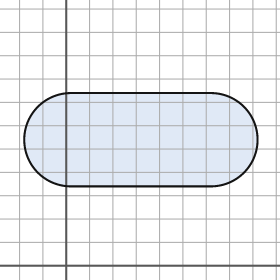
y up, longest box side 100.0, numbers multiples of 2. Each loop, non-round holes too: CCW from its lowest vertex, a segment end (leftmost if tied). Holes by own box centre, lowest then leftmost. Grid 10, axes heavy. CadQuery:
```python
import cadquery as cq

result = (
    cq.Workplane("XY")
    .moveTo(2.0, 34.0)
    .lineTo(62.0, 34.0)
    .threePointArc((82.0, 54.0), (62.0, 74.0))
    .lineTo(2.0, 74.0)
    .threePointArc((-18.0, 54.0), (2.0, 34.0))
    .close()
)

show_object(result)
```